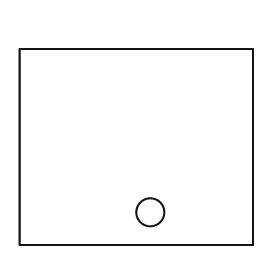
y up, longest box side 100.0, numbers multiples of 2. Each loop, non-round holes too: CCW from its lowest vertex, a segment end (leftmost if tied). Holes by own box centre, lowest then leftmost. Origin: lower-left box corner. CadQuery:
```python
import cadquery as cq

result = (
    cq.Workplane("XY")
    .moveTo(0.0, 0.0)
    .lineTo(100.0, 0.0)
    .lineTo(100.0, 84.0)
    .lineTo(0.0, 84.0)
    .close()
    .moveTo(56.0, 14.0)
    .circle(6.0)
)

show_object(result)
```